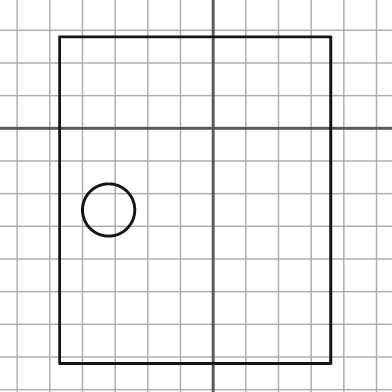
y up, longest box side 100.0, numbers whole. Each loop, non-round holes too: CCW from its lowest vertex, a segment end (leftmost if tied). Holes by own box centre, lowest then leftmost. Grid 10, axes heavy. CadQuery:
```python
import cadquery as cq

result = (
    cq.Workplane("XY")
    .moveTo(-47.0, -72.0)
    .lineTo(36.0, -72.0)
    .lineTo(36.0, 28.0)
    .lineTo(-47.0, 28.0)
    .close()
    .moveTo(-32.0, -25.0)
    .circle(8.0)
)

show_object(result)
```